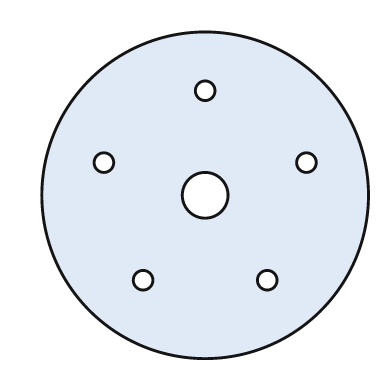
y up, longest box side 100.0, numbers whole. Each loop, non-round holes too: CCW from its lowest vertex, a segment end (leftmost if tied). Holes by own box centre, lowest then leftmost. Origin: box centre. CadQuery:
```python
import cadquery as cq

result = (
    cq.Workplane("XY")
    .moveTo(0.0, 0.0)
    .circle(50.0)
    .moveTo(-19.0, -26.0)
    .circle(3.0)
    .moveTo(19.0, -26.0)
    .circle(3.0)
    .moveTo(0.0, 0.0)
    .circle(7.0)
    .moveTo(-31.0, 10.0)
    .circle(3.0)
    .moveTo(31.0, 10.0)
    .circle(3.0)
    .moveTo(0.0, 32.0)
    .circle(3.0)
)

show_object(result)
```